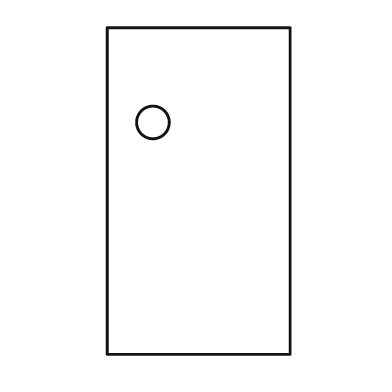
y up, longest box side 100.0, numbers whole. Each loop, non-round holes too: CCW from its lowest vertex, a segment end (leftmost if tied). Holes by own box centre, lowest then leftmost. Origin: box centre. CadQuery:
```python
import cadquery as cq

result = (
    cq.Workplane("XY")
    .moveTo(-28.0, -50.0)
    .lineTo(28.0, -50.0)
    .lineTo(28.0, 50.0)
    .lineTo(-28.0, 50.0)
    .close()
    .moveTo(-14.0, 21.0)
    .circle(5.0)
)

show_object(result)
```